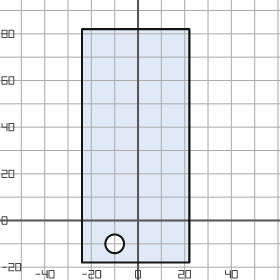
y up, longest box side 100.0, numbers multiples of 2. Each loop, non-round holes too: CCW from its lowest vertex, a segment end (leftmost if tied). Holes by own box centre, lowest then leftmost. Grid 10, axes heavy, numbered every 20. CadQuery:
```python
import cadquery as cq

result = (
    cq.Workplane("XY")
    .moveTo(-24.0, -18.0)
    .lineTo(22.0, -18.0)
    .lineTo(22.0, 82.0)
    .lineTo(-24.0, 82.0)
    .close()
    .moveTo(-10.0, -10.0)
    .circle(4.0)
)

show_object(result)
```